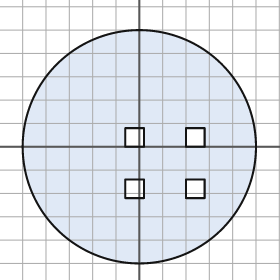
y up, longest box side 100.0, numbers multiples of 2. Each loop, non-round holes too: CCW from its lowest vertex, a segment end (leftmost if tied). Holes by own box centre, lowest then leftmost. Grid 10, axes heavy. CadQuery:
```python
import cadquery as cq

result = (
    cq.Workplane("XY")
    .moveTo(0.0, 0.0)
    .circle(50.0)
    .moveTo(-6.0, -22.0)
    .lineTo(2.0, -22.0)
    .lineTo(2.0, -14.0)
    .lineTo(-6.0, -14.0)
    .close()
    .moveTo(20.0, -22.0)
    .lineTo(28.0, -22.0)
    .lineTo(28.0, -14.0)
    .lineTo(20.0, -14.0)
    .close()
    .moveTo(-6.0, 0.0)
    .lineTo(2.0, 0.0)
    .lineTo(2.0, 8.0)
    .lineTo(-6.0, 8.0)
    .close()
    .moveTo(20.0, 0.0)
    .lineTo(28.0, 0.0)
    .lineTo(28.0, 8.0)
    .lineTo(20.0, 8.0)
    .close()
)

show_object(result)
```